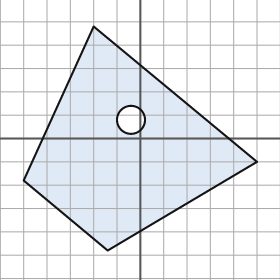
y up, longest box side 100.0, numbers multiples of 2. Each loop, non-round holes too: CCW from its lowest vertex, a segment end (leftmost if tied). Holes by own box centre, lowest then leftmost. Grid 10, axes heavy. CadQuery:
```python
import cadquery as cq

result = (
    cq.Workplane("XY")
    .moveTo(-14.0, -48.0)
    .lineTo(50.0, -10.0)
    .lineTo(-20.0, 48.0)
    .lineTo(-50.0, -18.0)
    .close()
    .moveTo(-4.0, 8.0)
    .circle(6.0)
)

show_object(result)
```